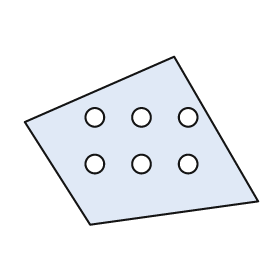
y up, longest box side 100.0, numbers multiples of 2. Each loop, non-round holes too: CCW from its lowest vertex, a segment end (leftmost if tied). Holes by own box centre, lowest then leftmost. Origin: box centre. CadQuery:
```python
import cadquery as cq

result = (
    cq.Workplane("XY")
    .moveTo(-22.0, -36.0)
    .lineTo(50.0, -26.0)
    .lineTo(14.0, 36.0)
    .lineTo(-50.0, 8.0)
    .close()
    .moveTo(-20.0, -10.0)
    .circle(4.0)
    .moveTo(0.0, -10.0)
    .circle(4.0)
    .moveTo(20.0, -10.0)
    .circle(4.0)
    .moveTo(-20.0, 10.0)
    .circle(4.0)
    .moveTo(0.0, 10.0)
    .circle(4.0)
    .moveTo(20.0, 10.0)
    .circle(4.0)
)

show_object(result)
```